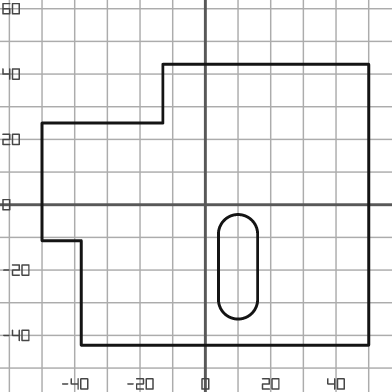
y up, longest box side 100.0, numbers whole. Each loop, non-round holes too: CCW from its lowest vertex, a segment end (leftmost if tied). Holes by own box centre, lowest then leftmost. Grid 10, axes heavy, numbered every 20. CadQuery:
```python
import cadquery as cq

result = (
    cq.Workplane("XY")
    .moveTo(-38.0, -43.0)
    .lineTo(50.0, -43.0)
    .lineTo(50.0, 43.0)
    .lineTo(-13.0, 43.0)
    .lineTo(-13.0, 25.0)
    .lineTo(-50.0, 25.0)
    .lineTo(-50.0, -11.0)
    .lineTo(-38.0, -11.0)
    .close()
    .moveTo(4.0, -29.0)
    .threePointArc((10.0, -35.0), (16.0, -29.0))
    .lineTo(16.0, -9.0)
    .threePointArc((10.0, -3.0), (4.0, -9.0))
    .close()
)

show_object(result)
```